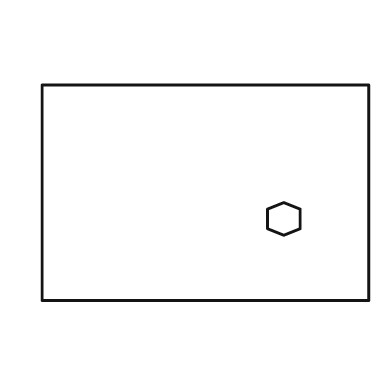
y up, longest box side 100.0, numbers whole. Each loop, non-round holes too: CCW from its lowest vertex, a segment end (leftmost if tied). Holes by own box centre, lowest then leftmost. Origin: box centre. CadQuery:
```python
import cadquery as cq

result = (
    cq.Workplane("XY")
    .moveTo(-50.0, -33.0)
    .lineTo(50.0, -33.0)
    .lineTo(50.0, 33.0)
    .lineTo(-50.0, 33.0)
    .close()
    .moveTo(24.0, -13.0)
    .lineTo(29.0, -11.0)
    .lineTo(29.0, -5.0)
    .lineTo(24.0, -3.0)
    .lineTo(19.0, -5.0)
    .lineTo(19.0, -11.0)
    .close()
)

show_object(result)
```